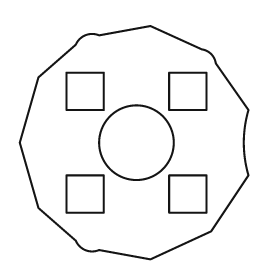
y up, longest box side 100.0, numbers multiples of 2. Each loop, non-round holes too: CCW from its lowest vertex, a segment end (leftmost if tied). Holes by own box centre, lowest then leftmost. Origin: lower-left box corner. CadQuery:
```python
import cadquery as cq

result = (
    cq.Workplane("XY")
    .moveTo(56.0, 0.0)
    .lineTo(82.0, 12.0)
    .lineTo(98.0, 36.0)
    .threePointArc((96.0, 50.0), (98.0, 64.0))
    .lineTo(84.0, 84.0)
    .threePointArc((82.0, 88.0), (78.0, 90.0))
    .lineTo(56.0, 100.0)
    .lineTo(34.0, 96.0)
    .threePointArc((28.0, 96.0), (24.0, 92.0))
    .lineTo(8.0, 78.0)
    .lineTo(0.0, 50.0)
    .lineTo(8.0, 22.0)
    .lineTo(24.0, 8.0)
    .threePointArc((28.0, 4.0), (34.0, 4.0))
    .close()
    .moveTo(20.0, 20.0)
    .lineTo(36.0, 20.0)
    .lineTo(36.0, 36.0)
    .lineTo(20.0, 36.0)
    .close()
    .moveTo(64.0, 20.0)
    .lineTo(80.0, 20.0)
    .lineTo(80.0, 36.0)
    .lineTo(64.0, 36.0)
    .close()
    .moveTo(50.0, 50.0)
    .circle(16.0)
    .moveTo(20.0, 64.0)
    .lineTo(36.0, 64.0)
    .lineTo(36.0, 80.0)
    .lineTo(20.0, 80.0)
    .close()
    .moveTo(64.0, 64.0)
    .lineTo(80.0, 64.0)
    .lineTo(80.0, 80.0)
    .lineTo(64.0, 80.0)
    .close()
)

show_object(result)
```